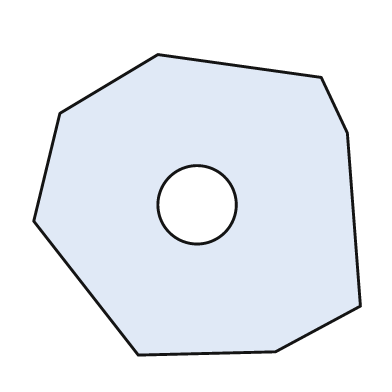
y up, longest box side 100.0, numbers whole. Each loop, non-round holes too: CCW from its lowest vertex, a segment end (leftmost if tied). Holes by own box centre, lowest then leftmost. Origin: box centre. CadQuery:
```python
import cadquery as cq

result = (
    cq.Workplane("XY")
    .moveTo(-18.0, -46.0)
    .lineTo(24.0, -45.0)
    .lineTo(50.0, -31.0)
    .lineTo(46.0, 22.0)
    .lineTo(38.0, 39.0)
    .lineTo(-12.0, 46.0)
    .lineTo(-42.0, 28.0)
    .lineTo(-50.0, -5.0)
    .close()
    .moveTo(0.0, 0.0)
    .circle(12.0)
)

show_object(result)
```